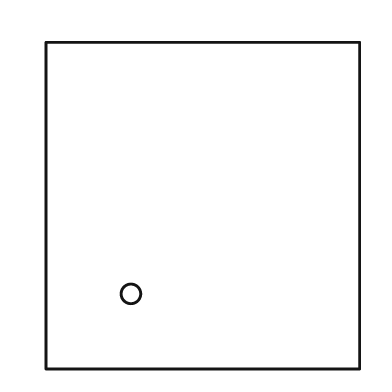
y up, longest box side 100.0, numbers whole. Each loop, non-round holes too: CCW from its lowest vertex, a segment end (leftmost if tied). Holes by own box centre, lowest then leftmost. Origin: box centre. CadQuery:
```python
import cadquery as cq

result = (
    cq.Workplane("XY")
    .moveTo(-48.0, -50.0)
    .lineTo(48.0, -50.0)
    .lineTo(48.0, 50.0)
    .lineTo(-48.0, 50.0)
    .close()
    .moveTo(-22.0, -27.0)
    .circle(3.0)
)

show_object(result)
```